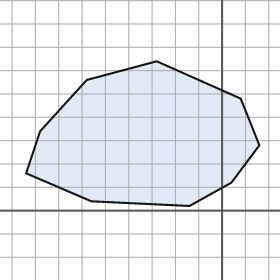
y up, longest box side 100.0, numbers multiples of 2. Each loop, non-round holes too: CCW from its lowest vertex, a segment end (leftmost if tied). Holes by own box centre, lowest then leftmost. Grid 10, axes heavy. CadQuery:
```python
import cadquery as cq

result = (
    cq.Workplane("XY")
    .moveTo(-14.0, 2.0)
    .lineTo(4.0, 12.0)
    .lineTo(16.0, 28.0)
    .lineTo(8.0, 48.0)
    .lineTo(-28.0, 64.0)
    .lineTo(-58.0, 56.0)
    .lineTo(-78.0, 34.0)
    .lineTo(-84.0, 16.0)
    .lineTo(-56.0, 4.0)
    .close()
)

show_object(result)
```